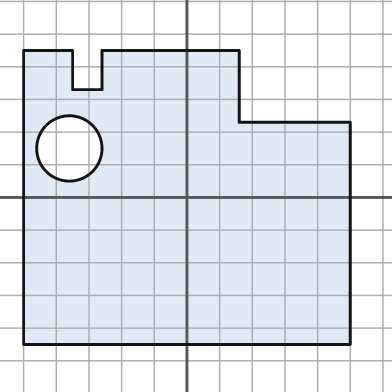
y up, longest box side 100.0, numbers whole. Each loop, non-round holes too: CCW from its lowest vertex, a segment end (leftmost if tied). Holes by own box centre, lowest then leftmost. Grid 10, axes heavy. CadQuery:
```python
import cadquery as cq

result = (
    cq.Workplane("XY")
    .moveTo(-50.0, -45.0)
    .lineTo(50.0, -45.0)
    .lineTo(50.0, 23.0)
    .lineTo(16.0, 23.0)
    .lineTo(16.0, 45.0)
    .lineTo(-26.0, 45.0)
    .lineTo(-26.0, 33.0)
    .lineTo(-35.0, 33.0)
    .lineTo(-35.0, 45.0)
    .lineTo(-50.0, 45.0)
    .close()
    .moveTo(-36.0, 15.0)
    .circle(10.0)
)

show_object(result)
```